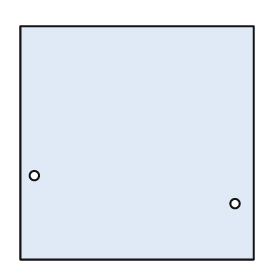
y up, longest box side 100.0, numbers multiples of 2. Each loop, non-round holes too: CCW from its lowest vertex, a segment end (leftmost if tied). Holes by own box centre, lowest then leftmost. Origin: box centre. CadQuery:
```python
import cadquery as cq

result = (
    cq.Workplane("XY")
    .moveTo(-50.0, -50.0)
    .lineTo(50.0, -50.0)
    .lineTo(50.0, 50.0)
    .lineTo(-50.0, 50.0)
    .close()
    .moveTo(42.0, -26.0)
    .circle(2.0)
    .moveTo(-44.0, -14.0)
    .circle(2.0)
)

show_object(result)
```